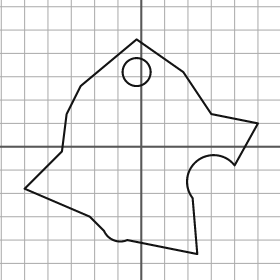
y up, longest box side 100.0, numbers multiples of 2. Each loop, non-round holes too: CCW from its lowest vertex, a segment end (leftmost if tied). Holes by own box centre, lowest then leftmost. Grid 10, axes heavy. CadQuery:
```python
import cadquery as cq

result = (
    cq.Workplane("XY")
    .moveTo(24.0, -46.0)
    .lineTo(22.0, -22.0)
    .threePointArc((24.0, -6.0), (40.0, -8.0))
    .lineTo(50.0, 10.0)
    .lineTo(30.0, 14.0)
    .lineTo(18.0, 32.0)
    .lineTo(-2.0, 46.0)
    .lineTo(-26.0, 26.0)
    .lineTo(-32.0, 14.0)
    .lineTo(-34.0, -2.0)
    .lineTo(-50.0, -18.0)
    .lineTo(-22.0, -30.0)
    .lineTo(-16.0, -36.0)
    .threePointArc((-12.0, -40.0), (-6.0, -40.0))
    .close()
    .moveTo(-2.0, 32.0)
    .circle(6.0)
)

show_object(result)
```